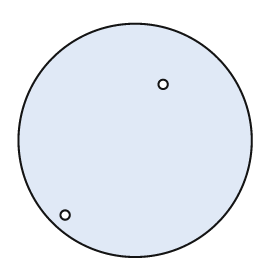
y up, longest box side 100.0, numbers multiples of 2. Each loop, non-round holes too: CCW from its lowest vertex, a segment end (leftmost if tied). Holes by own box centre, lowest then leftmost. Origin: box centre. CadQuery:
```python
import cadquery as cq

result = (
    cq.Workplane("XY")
    .moveTo(0.0, 0.0)
    .circle(50.0)
    .moveTo(-30.0, -32.0)
    .circle(2.0)
    .moveTo(12.0, 24.0)
    .circle(2.0)
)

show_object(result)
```